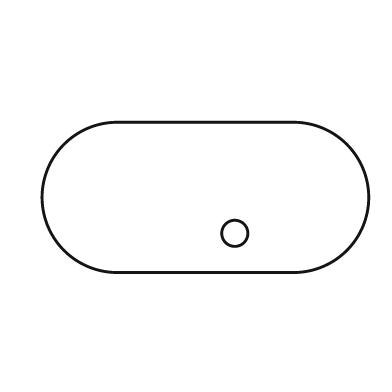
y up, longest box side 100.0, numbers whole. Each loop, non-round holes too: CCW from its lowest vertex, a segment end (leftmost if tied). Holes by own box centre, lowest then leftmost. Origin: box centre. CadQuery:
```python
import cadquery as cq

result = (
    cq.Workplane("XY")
    .moveTo(-27.0, -23.0)
    .lineTo(27.0, -23.0)
    .threePointArc((50.0, 0.0), (27.0, 23.0))
    .lineTo(-27.0, 23.0)
    .threePointArc((-50.0, 0.0), (-27.0, -23.0))
    .close()
    .moveTo(9.0, -11.0)
    .circle(4.0)
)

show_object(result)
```